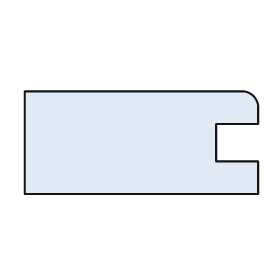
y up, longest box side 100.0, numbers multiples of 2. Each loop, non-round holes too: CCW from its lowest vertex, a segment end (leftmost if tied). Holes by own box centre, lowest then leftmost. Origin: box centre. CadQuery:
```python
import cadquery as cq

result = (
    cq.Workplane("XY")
    .moveTo(-50.0, -22.0)
    .lineTo(50.0, -22.0)
    .lineTo(50.0, -8.0)
    .lineTo(32.0, -8.0)
    .lineTo(32.0, 8.0)
    .lineTo(50.0, 8.0)
    .lineTo(50.0, 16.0)
    .threePointArc((48.0, 20.0), (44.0, 22.0))
    .lineTo(-50.0, 22.0)
    .close()
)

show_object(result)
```